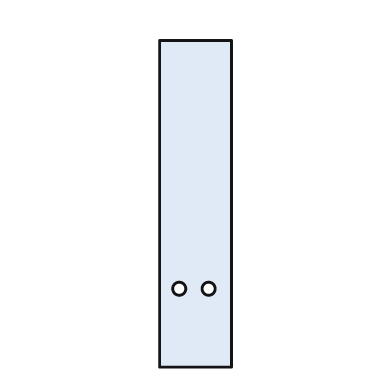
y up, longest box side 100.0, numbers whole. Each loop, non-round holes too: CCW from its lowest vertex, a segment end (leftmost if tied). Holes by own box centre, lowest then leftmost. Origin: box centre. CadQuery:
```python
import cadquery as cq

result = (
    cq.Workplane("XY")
    .moveTo(-11.0, -50.0)
    .lineTo(11.0, -50.0)
    .lineTo(11.0, 50.0)
    .lineTo(-11.0, 50.0)
    .close()
    .moveTo(-5.0, -26.0)
    .circle(2.0)
    .moveTo(4.0, -26.0)
    .circle(2.0)
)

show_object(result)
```